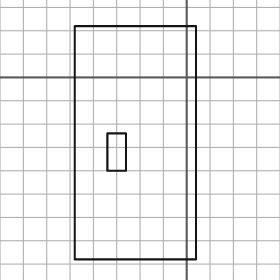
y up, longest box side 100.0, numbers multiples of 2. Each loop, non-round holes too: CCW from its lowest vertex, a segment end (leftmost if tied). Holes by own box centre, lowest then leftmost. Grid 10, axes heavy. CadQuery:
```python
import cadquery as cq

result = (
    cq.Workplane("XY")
    .moveTo(-48.0, -78.0)
    .lineTo(4.0, -78.0)
    .lineTo(4.0, 22.0)
    .lineTo(-48.0, 22.0)
    .close()
    .moveTo(-34.0, -40.0)
    .lineTo(-26.0, -40.0)
    .lineTo(-26.0, -24.0)
    .lineTo(-34.0, -24.0)
    .close()
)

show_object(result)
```